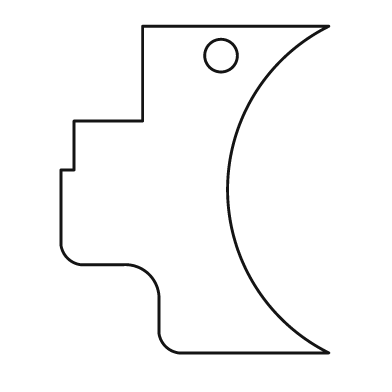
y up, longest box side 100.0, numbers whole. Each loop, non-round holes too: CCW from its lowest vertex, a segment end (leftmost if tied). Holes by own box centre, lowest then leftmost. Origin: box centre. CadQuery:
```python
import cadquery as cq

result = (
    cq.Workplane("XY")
    .moveTo(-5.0, -50.0)
    .lineTo(41.0, -50.0)
    .threePointArc((10.0, 0.0), (41.0, 50.0))
    .lineTo(-16.0, 50.0)
    .lineTo(-16.0, 21.0)
    .lineTo(-37.0, 21.0)
    .lineTo(-37.0, 6.0)
    .lineTo(-41.0, 6.0)
    .lineTo(-41.0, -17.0)
    .threePointArc((-39.0, -21.0), (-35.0, -23.0))
    .lineTo(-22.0, -23.0)
    .threePointArc((-14.0, -26.0), (-11.0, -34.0))
    .lineTo(-11.0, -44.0)
    .threePointArc((-9.0, -48.0), (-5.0, -50.0))
    .close()
    .moveTo(8.0, 41.0)
    .circle(5.0)
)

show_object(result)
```